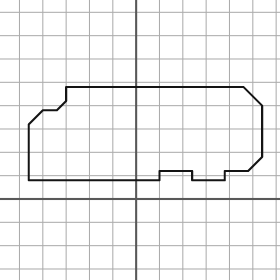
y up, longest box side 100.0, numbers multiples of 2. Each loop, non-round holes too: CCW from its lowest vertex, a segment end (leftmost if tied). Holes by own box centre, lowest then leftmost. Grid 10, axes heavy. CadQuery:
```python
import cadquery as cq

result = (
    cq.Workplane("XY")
    .moveTo(-46.0, 8.0)
    .lineTo(10.0, 8.0)
    .lineTo(10.0, 12.0)
    .lineTo(24.0, 12.0)
    .lineTo(24.0, 8.0)
    .lineTo(38.0, 8.0)
    .lineTo(38.0, 12.0)
    .lineTo(48.0, 12.0)
    .lineTo(54.0, 18.0)
    .lineTo(54.0, 40.0)
    .lineTo(46.0, 48.0)
    .lineTo(-30.0, 48.0)
    .lineTo(-30.0, 42.0)
    .lineTo(-34.0, 38.0)
    .lineTo(-40.0, 38.0)
    .lineTo(-46.0, 32.0)
    .close()
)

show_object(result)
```